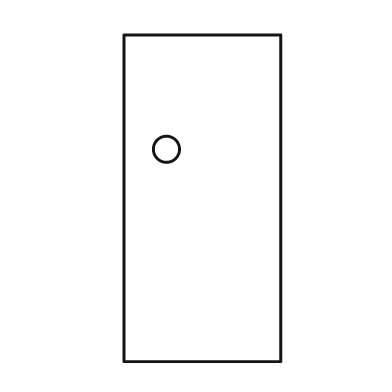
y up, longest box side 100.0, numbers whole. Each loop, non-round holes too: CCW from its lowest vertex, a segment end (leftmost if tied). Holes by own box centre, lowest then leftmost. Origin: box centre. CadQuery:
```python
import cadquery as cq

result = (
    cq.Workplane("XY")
    .moveTo(-24.0, -50.0)
    .lineTo(24.0, -50.0)
    .lineTo(24.0, 50.0)
    .lineTo(-24.0, 50.0)
    .close()
    .moveTo(-11.0, 15.0)
    .circle(4.0)
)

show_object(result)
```